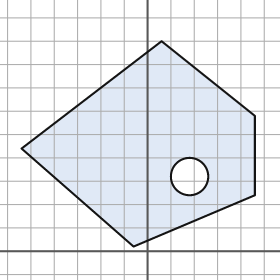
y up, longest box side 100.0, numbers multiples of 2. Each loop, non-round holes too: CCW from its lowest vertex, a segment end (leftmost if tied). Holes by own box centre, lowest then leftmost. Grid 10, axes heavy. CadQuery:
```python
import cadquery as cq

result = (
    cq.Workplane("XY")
    .moveTo(-6.0, 2.0)
    .lineTo(46.0, 24.0)
    .lineTo(46.0, 58.0)
    .lineTo(6.0, 90.0)
    .lineTo(-54.0, 44.0)
    .close()
    .moveTo(18.0, 32.0)
    .circle(8.0)
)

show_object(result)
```